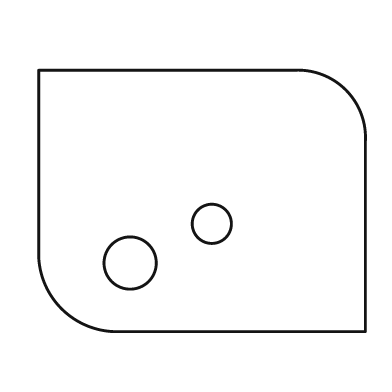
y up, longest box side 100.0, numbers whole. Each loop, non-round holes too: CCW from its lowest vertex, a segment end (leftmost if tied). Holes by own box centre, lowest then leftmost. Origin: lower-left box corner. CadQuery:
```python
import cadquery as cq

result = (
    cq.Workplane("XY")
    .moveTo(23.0, 0.0)
    .lineTo(100.0, 0.0)
    .lineTo(100.0, 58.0)
    .threePointArc((94.0, 74.0), (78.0, 80.0))
    .lineTo(0.0, 80.0)
    .lineTo(0.0, 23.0)
    .threePointArc((7.0, 7.0), (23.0, 0.0))
    .close()
    .moveTo(28.0, 21.0)
    .circle(8.0)
    .moveTo(53.0, 33.0)
    .circle(6.0)
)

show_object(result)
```